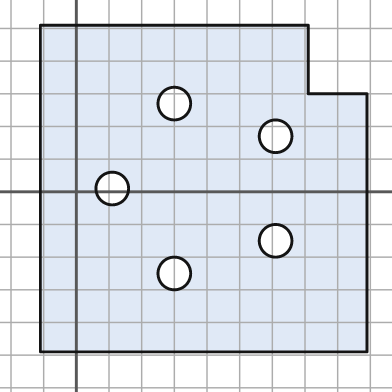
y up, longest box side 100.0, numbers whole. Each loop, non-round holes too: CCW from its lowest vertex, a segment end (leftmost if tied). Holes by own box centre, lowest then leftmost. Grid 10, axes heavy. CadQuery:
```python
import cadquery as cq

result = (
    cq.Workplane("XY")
    .moveTo(-11.0, -49.0)
    .lineTo(89.0, -49.0)
    .lineTo(89.0, 30.0)
    .lineTo(71.0, 30.0)
    .lineTo(71.0, 51.0)
    .lineTo(-11.0, 51.0)
    .close()
    .moveTo(30.0, -25.0)
    .circle(5.0)
    .moveTo(61.0, -15.0)
    .circle(5.0)
    .moveTo(11.0, 1.0)
    .circle(5.0)
    .moveTo(61.0, 17.0)
    .circle(5.0)
    .moveTo(30.0, 27.0)
    .circle(5.0)
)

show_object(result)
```